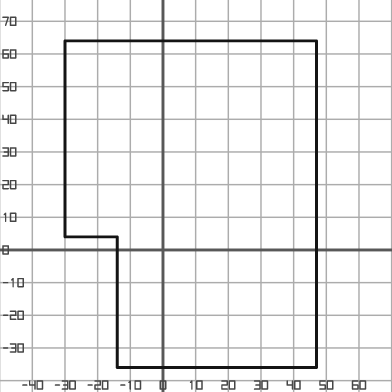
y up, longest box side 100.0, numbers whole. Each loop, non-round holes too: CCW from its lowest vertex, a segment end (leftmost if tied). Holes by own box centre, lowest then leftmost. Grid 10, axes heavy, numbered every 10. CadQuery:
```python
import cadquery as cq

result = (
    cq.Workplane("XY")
    .moveTo(-14.0, -36.0)
    .lineTo(47.0, -36.0)
    .lineTo(47.0, 64.0)
    .lineTo(-30.0, 64.0)
    .lineTo(-30.0, 4.0)
    .lineTo(-14.0, 4.0)
    .close()
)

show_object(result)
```